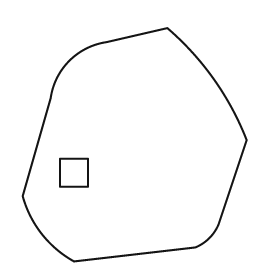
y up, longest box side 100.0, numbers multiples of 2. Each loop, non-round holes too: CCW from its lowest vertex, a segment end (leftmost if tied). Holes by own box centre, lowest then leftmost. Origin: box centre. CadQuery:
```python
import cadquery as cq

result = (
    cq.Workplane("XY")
    .moveTo(-26.0, -50.0)
    .lineTo(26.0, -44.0)
    .threePointArc((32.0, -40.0), (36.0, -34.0))
    .lineTo(48.0, 2.0)
    .threePointArc((34.0, 28.0), (14.0, 50.0))
    .lineTo(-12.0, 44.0)
    .threePointArc((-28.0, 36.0), (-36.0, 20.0))
    .lineTo(-48.0, -22.0)
    .threePointArc((-40.0, -38.0), (-26.0, -50.0))
    .close()
    .moveTo(-32.0, -18.0)
    .lineTo(-20.0, -18.0)
    .lineTo(-20.0, -6.0)
    .lineTo(-32.0, -6.0)
    .close()
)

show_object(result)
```